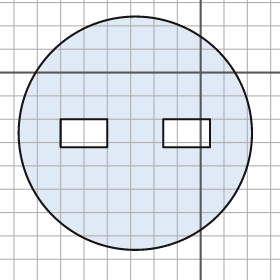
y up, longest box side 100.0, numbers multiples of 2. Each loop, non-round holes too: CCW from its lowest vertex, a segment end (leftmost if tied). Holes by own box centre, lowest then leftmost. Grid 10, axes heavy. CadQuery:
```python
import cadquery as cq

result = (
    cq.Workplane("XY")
    .moveTo(-28.0, -26.0)
    .circle(50.0)
    .moveTo(-60.0, -32.0)
    .lineTo(-40.0, -32.0)
    .lineTo(-40.0, -20.0)
    .lineTo(-60.0, -20.0)
    .close()
    .moveTo(-16.0, -32.0)
    .lineTo(4.0, -32.0)
    .lineTo(4.0, -20.0)
    .lineTo(-16.0, -20.0)
    .close()
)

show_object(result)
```